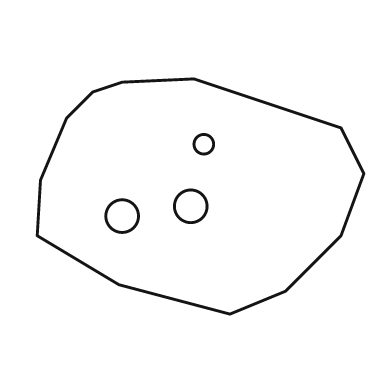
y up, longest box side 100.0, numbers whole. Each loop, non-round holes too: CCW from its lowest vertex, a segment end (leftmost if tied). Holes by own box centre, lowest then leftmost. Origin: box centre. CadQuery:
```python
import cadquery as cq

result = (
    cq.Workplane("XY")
    .moveTo(9.0, -36.0)
    .lineTo(26.0, -29.0)
    .lineTo(43.0, -12.0)
    .lineTo(50.0, 7.0)
    .lineTo(43.0, 21.0)
    .lineTo(-2.0, 36.0)
    .lineTo(-24.0, 35.0)
    .lineTo(-33.0, 32.0)
    .lineTo(-41.0, 24.0)
    .lineTo(-49.0, 5.0)
    .lineTo(-50.0, -12.0)
    .lineTo(-25.0, -27.0)
    .close()
    .moveTo(-24.0, -6.0)
    .circle(5.0)
    .moveTo(-3.0, -3.0)
    .circle(5.0)
    .moveTo(1.0, 16.0)
    .circle(3.0)
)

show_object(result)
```